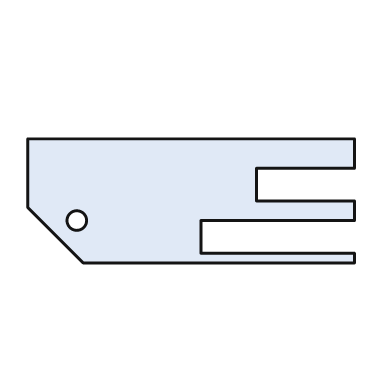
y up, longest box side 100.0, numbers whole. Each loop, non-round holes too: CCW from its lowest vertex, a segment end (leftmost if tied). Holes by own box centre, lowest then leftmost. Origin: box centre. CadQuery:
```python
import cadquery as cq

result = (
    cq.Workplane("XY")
    .moveTo(-33.0, -19.0)
    .lineTo(50.0, -19.0)
    .lineTo(50.0, -16.0)
    .lineTo(3.0, -16.0)
    .lineTo(3.0, -6.0)
    .lineTo(50.0, -6.0)
    .lineTo(50.0, 0.0)
    .lineTo(20.0, 0.0)
    .lineTo(20.0, 10.0)
    .lineTo(50.0, 10.0)
    .lineTo(50.0, 19.0)
    .lineTo(-50.0, 19.0)
    .lineTo(-50.0, -2.0)
    .close()
    .moveTo(-35.0, -6.0)
    .circle(3.0)
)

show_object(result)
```